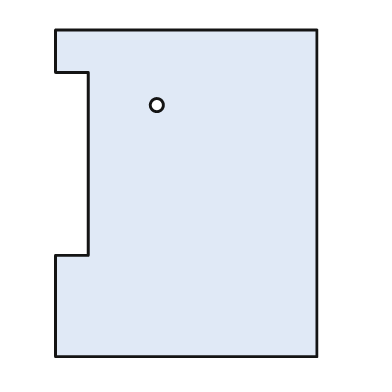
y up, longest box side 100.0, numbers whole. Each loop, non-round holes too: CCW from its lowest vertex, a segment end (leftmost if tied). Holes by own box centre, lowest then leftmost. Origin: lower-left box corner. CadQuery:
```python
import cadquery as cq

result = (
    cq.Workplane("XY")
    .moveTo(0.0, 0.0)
    .lineTo(80.0, 0.0)
    .lineTo(80.0, 100.0)
    .lineTo(0.0, 100.0)
    .lineTo(0.0, 87.0)
    .lineTo(10.0, 87.0)
    .lineTo(10.0, 31.0)
    .lineTo(0.0, 31.0)
    .close()
    .moveTo(31.0, 77.0)
    .circle(2.0)
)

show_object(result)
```